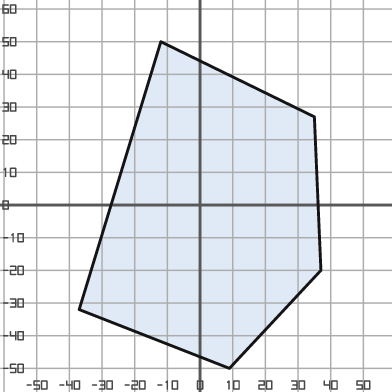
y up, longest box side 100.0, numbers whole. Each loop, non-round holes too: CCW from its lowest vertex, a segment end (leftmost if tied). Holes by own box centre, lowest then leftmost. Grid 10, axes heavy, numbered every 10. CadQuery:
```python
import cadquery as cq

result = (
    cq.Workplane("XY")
    .moveTo(9.0, -50.0)
    .lineTo(37.0, -20.0)
    .lineTo(35.0, 27.0)
    .lineTo(-12.0, 50.0)
    .lineTo(-37.0, -32.0)
    .close()
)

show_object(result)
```